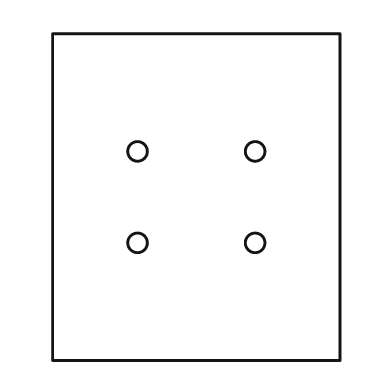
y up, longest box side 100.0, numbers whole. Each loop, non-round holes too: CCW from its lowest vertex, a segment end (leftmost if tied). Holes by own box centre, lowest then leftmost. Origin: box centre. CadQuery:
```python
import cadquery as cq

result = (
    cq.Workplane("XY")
    .moveTo(-44.0, -50.0)
    .lineTo(44.0, -50.0)
    .lineTo(44.0, 50.0)
    .lineTo(-44.0, 50.0)
    .close()
    .moveTo(-18.0, -14.0)
    .circle(3.0)
    .moveTo(18.0, -14.0)
    .circle(3.0)
    .moveTo(-18.0, 14.0)
    .circle(3.0)
    .moveTo(18.0, 14.0)
    .circle(3.0)
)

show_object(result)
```